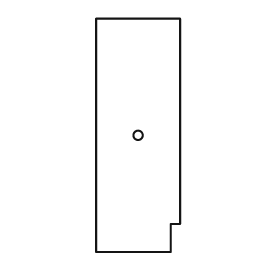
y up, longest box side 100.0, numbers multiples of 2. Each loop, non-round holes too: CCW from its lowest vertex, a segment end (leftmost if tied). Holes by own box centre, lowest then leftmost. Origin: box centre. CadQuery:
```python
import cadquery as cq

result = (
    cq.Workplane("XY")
    .moveTo(-18.0, -50.0)
    .lineTo(14.0, -50.0)
    .lineTo(14.0, -38.0)
    .lineTo(18.0, -38.0)
    .lineTo(18.0, 50.0)
    .lineTo(-18.0, 50.0)
    .close()
    .moveTo(0.0, 0.0)
    .circle(2.0)
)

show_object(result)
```